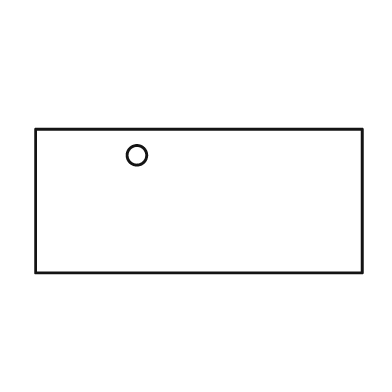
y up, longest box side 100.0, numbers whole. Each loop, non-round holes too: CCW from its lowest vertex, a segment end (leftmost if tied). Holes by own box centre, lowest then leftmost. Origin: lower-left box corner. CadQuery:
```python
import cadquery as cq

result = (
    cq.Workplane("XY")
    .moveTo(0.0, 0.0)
    .lineTo(100.0, 0.0)
    .lineTo(100.0, 44.0)
    .lineTo(0.0, 44.0)
    .close()
    .moveTo(31.0, 36.0)
    .circle(3.0)
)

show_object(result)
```